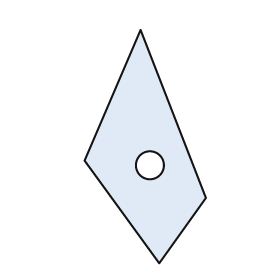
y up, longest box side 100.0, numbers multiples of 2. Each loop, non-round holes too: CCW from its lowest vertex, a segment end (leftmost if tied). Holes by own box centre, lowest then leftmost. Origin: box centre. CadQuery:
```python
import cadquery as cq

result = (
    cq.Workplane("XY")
    .moveTo(6.0, -50.0)
    .lineTo(26.0, -22.0)
    .lineTo(-2.0, 50.0)
    .lineTo(-26.0, -6.0)
    .close()
    .moveTo(2.0, -8.0)
    .circle(6.0)
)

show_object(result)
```